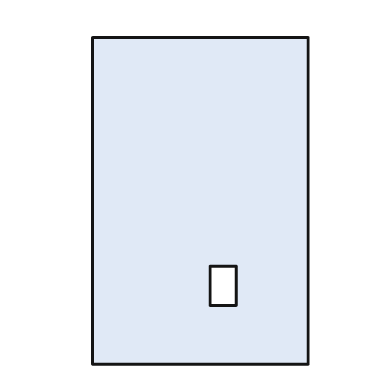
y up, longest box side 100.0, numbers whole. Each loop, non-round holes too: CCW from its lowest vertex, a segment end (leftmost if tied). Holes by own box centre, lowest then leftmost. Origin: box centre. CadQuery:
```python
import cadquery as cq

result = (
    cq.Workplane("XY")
    .moveTo(-33.0, -50.0)
    .lineTo(33.0, -50.0)
    .lineTo(33.0, 50.0)
    .lineTo(-33.0, 50.0)
    .close()
    .moveTo(3.0, -32.0)
    .lineTo(11.0, -32.0)
    .lineTo(11.0, -20.0)
    .lineTo(3.0, -20.0)
    .close()
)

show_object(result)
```